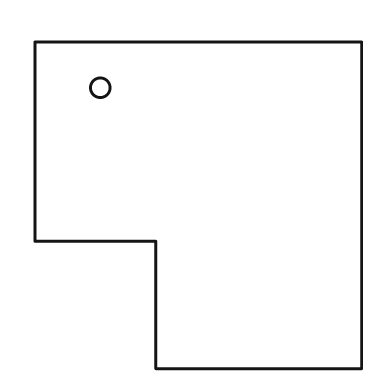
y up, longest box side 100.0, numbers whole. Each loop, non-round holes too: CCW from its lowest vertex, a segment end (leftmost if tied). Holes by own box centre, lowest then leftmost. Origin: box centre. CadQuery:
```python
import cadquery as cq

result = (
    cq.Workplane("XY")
    .moveTo(-13.0, -50.0)
    .lineTo(50.0, -50.0)
    .lineTo(50.0, 50.0)
    .lineTo(-50.0, 50.0)
    .lineTo(-50.0, -11.0)
    .lineTo(-13.0, -11.0)
    .close()
    .moveTo(-30.0, 36.0)
    .circle(3.0)
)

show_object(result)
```